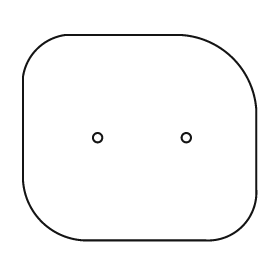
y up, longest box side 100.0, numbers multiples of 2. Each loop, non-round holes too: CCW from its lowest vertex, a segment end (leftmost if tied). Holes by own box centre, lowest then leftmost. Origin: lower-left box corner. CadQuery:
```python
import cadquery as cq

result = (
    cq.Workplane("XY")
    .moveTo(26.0, 0.0)
    .lineTo(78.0, 0.0)
    .threePointArc((94.0, 6.0), (100.0, 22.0))
    .lineTo(100.0, 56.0)
    .threePointArc((90.0, 78.0), (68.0, 88.0))
    .lineTo(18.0, 88.0)
    .threePointArc((6.0, 82.0), (0.0, 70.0))
    .lineTo(0.0, 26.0)
    .threePointArc((8.0, 8.0), (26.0, 0.0))
    .close()
    .moveTo(32.0, 44.0)
    .circle(2.0)
    .moveTo(70.0, 44.0)
    .circle(2.0)
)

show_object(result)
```